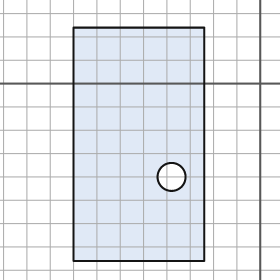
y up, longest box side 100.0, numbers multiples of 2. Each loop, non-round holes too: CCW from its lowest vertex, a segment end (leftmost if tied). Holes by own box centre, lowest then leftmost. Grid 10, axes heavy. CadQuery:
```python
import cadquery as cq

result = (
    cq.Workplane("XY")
    .moveTo(-80.0, -76.0)
    .lineTo(-24.0, -76.0)
    .lineTo(-24.0, 24.0)
    .lineTo(-80.0, 24.0)
    .close()
    .moveTo(-38.0, -40.0)
    .circle(6.0)
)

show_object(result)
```